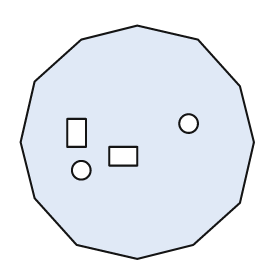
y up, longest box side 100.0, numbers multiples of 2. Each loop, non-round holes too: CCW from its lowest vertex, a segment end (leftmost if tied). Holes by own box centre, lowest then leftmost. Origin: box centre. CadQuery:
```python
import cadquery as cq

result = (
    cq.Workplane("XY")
    .moveTo(0.0, -50.0)
    .lineTo(24.0, -44.0)
    .lineTo(44.0, -26.0)
    .lineTo(50.0, 0.0)
    .lineTo(44.0, 24.0)
    .lineTo(26.0, 44.0)
    .lineTo(0.0, 50.0)
    .lineTo(-24.0, 44.0)
    .lineTo(-44.0, 26.0)
    .lineTo(-50.0, 0.0)
    .lineTo(-44.0, -24.0)
    .lineTo(-26.0, -44.0)
    .close()
    .moveTo(-24.0, -12.0)
    .circle(4.0)
    .moveTo(-12.0, -10.0)
    .lineTo(0.0, -10.0)
    .lineTo(0.0, -2.0)
    .lineTo(-12.0, -2.0)
    .close()
    .moveTo(-30.0, -2.0)
    .lineTo(-22.0, -2.0)
    .lineTo(-22.0, 10.0)
    .lineTo(-30.0, 10.0)
    .close()
    .moveTo(22.0, 8.0)
    .circle(4.0)
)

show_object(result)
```